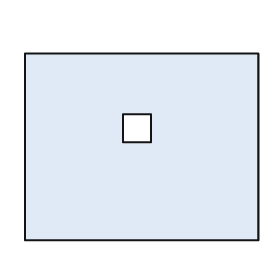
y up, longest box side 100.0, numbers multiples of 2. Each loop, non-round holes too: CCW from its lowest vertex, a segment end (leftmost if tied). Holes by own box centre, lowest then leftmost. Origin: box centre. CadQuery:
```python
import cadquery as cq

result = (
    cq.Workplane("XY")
    .moveTo(-50.0, -40.0)
    .lineTo(50.0, -40.0)
    .lineTo(50.0, 40.0)
    .lineTo(-50.0, 40.0)
    .close()
    .moveTo(-8.0, 2.0)
    .lineTo(4.0, 2.0)
    .lineTo(4.0, 14.0)
    .lineTo(-8.0, 14.0)
    .close()
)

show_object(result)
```